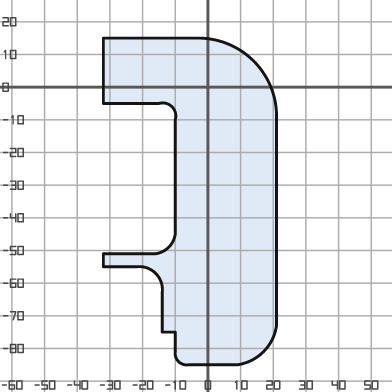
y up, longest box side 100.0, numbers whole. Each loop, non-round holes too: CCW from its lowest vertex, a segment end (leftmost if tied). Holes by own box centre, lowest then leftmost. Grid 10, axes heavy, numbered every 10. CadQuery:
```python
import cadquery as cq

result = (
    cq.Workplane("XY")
    .moveTo(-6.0, -85.0)
    .lineTo(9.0, -85.0)
    .threePointArc((17.0, -81.0), (21.0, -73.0))
    .lineTo(21.0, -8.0)
    .threePointArc((14.0, 8.0), (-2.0, 15.0))
    .lineTo(-32.0, 15.0)
    .lineTo(-32.0, -5.0)
    .lineTo(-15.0, -5.0)
    .threePointArc((-11.0, -6.0), (-10.0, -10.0))
    .lineTo(-10.0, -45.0)
    .threePointArc((-12.0, -49.0), (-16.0, -51.0))
    .lineTo(-32.0, -51.0)
    .lineTo(-32.0, -55.0)
    .lineTo(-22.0, -55.0)
    .threePointArc((-16.0, -57.0), (-14.0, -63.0))
    .lineTo(-14.0, -75.0)
    .lineTo(-10.0, -75.0)
    .lineTo(-10.0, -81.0)
    .threePointArc((-9.0, -84.0), (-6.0, -85.0))
    .close()
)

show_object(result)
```